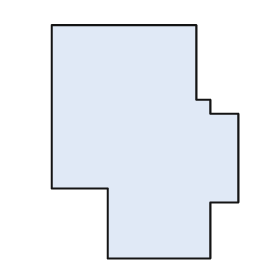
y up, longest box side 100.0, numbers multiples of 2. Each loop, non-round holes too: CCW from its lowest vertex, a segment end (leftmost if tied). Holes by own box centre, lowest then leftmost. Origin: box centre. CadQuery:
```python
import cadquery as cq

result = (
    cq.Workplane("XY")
    .moveTo(-16.0, -50.0)
    .lineTo(28.0, -50.0)
    .lineTo(28.0, -26.0)
    .lineTo(40.0, -26.0)
    .lineTo(40.0, 12.0)
    .lineTo(28.0, 12.0)
    .lineTo(28.0, 18.0)
    .lineTo(22.0, 18.0)
    .lineTo(22.0, 50.0)
    .lineTo(-40.0, 50.0)
    .lineTo(-40.0, -20.0)
    .lineTo(-16.0, -20.0)
    .close()
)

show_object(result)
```